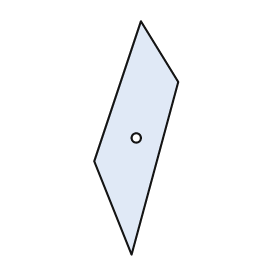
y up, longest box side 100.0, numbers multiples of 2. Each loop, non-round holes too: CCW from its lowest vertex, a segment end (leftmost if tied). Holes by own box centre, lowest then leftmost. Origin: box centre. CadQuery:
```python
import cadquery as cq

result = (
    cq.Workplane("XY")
    .moveTo(-2.0, -50.0)
    .lineTo(18.0, 24.0)
    .lineTo(2.0, 50.0)
    .lineTo(-18.0, -10.0)
    .close()
    .moveTo(0.0, 0.0)
    .circle(2.0)
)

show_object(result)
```